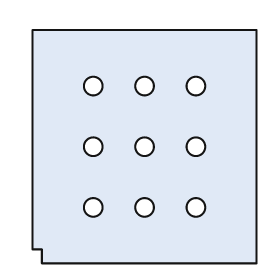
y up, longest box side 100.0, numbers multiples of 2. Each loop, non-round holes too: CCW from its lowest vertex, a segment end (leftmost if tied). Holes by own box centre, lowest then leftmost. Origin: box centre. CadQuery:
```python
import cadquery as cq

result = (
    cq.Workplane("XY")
    .moveTo(-44.0, -50.0)
    .lineTo(48.0, -50.0)
    .lineTo(48.0, 50.0)
    .lineTo(-48.0, 50.0)
    .lineTo(-48.0, -44.0)
    .lineTo(-44.0, -44.0)
    .close()
    .moveTo(-22.0, -26.0)
    .circle(4.0)
    .moveTo(0.0, -26.0)
    .circle(4.0)
    .moveTo(22.0, -26.0)
    .circle(4.0)
    .moveTo(-22.0, 0.0)
    .circle(4.0)
    .moveTo(0.0, 0.0)
    .circle(4.0)
    .moveTo(22.0, 0.0)
    .circle(4.0)
    .moveTo(-22.0, 26.0)
    .circle(4.0)
    .moveTo(0.0, 26.0)
    .circle(4.0)
    .moveTo(22.0, 26.0)
    .circle(4.0)
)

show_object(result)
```